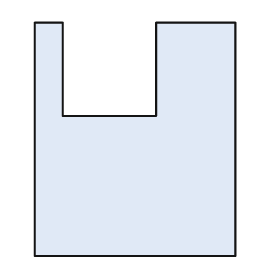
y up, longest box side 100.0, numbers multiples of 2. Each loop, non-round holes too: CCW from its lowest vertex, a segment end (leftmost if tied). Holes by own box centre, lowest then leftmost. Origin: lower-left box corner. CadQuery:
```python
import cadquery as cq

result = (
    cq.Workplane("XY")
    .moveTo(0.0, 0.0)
    .lineTo(86.0, 0.0)
    .lineTo(86.0, 100.0)
    .lineTo(52.0, 100.0)
    .lineTo(52.0, 60.0)
    .lineTo(12.0, 60.0)
    .lineTo(12.0, 100.0)
    .lineTo(0.0, 100.0)
    .close()
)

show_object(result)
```